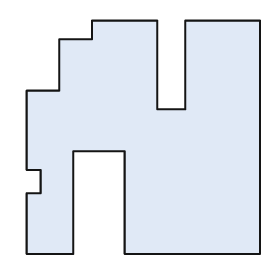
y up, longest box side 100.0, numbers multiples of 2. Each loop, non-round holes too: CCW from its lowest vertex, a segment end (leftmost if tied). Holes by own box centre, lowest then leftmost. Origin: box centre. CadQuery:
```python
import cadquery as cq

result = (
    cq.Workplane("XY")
    .moveTo(-50.0, -50.0)
    .lineTo(-30.0, -50.0)
    .lineTo(-30.0, -6.0)
    .lineTo(-8.0, -6.0)
    .lineTo(-8.0, -50.0)
    .lineTo(50.0, -50.0)
    .lineTo(50.0, 50.0)
    .lineTo(18.0, 50.0)
    .lineTo(18.0, 12.0)
    .lineTo(6.0, 12.0)
    .lineTo(6.0, 50.0)
    .lineTo(-22.0, 50.0)
    .lineTo(-22.0, 42.0)
    .lineTo(-36.0, 42.0)
    .lineTo(-36.0, 20.0)
    .lineTo(-50.0, 20.0)
    .lineTo(-50.0, -14.0)
    .lineTo(-44.0, -14.0)
    .lineTo(-44.0, -24.0)
    .lineTo(-50.0, -24.0)
    .close()
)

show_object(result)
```